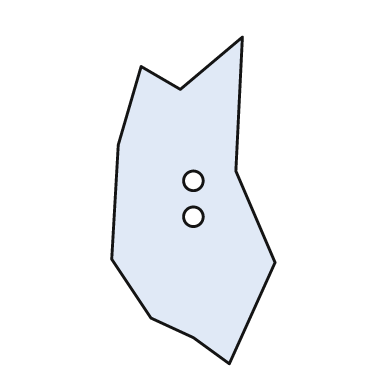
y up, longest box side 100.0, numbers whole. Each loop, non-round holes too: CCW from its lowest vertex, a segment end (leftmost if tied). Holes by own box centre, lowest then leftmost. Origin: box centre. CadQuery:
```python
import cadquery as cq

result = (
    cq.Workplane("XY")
    .moveTo(11.0, -50.0)
    .lineTo(25.0, -19.0)
    .lineTo(13.0, 9.0)
    .lineTo(15.0, 50.0)
    .lineTo(-4.0, 34.0)
    .lineTo(-16.0, 41.0)
    .lineTo(-23.0, 17.0)
    .lineTo(-25.0, -18.0)
    .lineTo(-13.0, -36.0)
    .lineTo(0.0, -42.0)
    .close()
    .moveTo(0.0, -5.0)
    .circle(3.0)
    .moveTo(0.0, 6.0)
    .circle(3.0)
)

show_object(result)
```